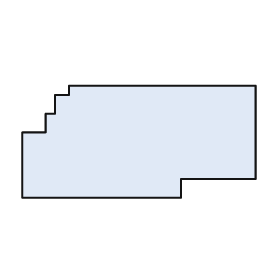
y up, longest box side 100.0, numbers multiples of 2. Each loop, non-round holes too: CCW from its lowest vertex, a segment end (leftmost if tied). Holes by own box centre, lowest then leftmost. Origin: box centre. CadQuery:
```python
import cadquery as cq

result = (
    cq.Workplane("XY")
    .moveTo(-50.0, -24.0)
    .lineTo(18.0, -24.0)
    .lineTo(18.0, -16.0)
    .lineTo(50.0, -16.0)
    .lineTo(50.0, 24.0)
    .lineTo(-30.0, 24.0)
    .lineTo(-30.0, 20.0)
    .lineTo(-36.0, 20.0)
    .lineTo(-36.0, 12.0)
    .lineTo(-40.0, 12.0)
    .lineTo(-40.0, 4.0)
    .lineTo(-50.0, 4.0)
    .close()
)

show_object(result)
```